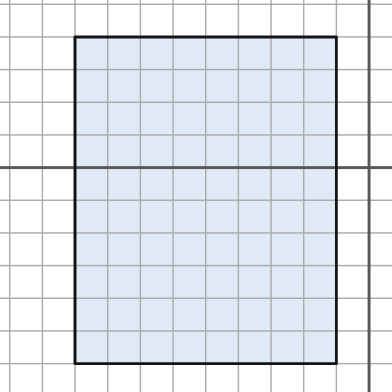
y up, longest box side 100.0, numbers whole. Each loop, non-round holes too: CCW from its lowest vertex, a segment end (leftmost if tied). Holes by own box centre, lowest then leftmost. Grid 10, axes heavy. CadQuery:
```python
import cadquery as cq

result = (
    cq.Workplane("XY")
    .moveTo(-90.0, -60.0)
    .lineTo(-10.0, -60.0)
    .lineTo(-10.0, 40.0)
    .lineTo(-90.0, 40.0)
    .close()
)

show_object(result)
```